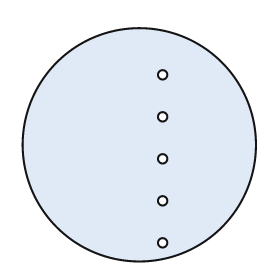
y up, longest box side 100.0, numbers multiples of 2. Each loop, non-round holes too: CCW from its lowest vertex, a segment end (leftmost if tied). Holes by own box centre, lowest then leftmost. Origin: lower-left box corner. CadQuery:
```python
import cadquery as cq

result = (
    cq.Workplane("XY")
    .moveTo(50.0, 50.0)
    .circle(50.0)
    .moveTo(60.0, 8.0)
    .circle(2.0)
    .moveTo(60.0, 26.0)
    .circle(2.0)
    .moveTo(60.0, 44.0)
    .circle(2.0)
    .moveTo(60.0, 62.0)
    .circle(2.0)
    .moveTo(60.0, 80.0)
    .circle(2.0)
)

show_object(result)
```